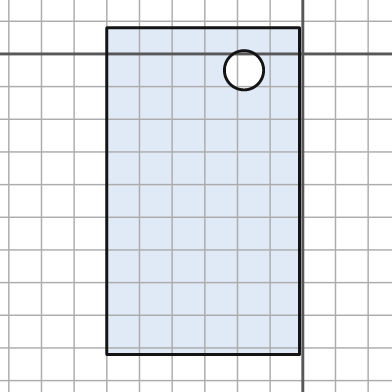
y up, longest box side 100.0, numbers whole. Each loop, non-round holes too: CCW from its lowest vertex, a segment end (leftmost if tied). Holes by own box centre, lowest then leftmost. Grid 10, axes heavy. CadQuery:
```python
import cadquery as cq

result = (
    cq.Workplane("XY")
    .moveTo(-60.0, -92.0)
    .lineTo(-1.0, -92.0)
    .lineTo(-1.0, 8.0)
    .lineTo(-60.0, 8.0)
    .close()
    .moveTo(-18.0, -5.0)
    .circle(6.0)
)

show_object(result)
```